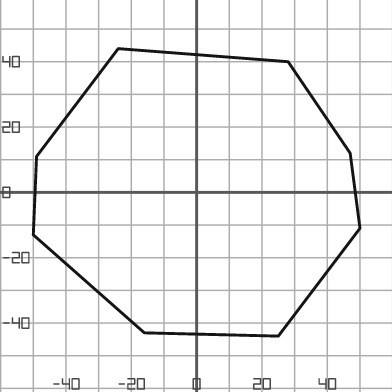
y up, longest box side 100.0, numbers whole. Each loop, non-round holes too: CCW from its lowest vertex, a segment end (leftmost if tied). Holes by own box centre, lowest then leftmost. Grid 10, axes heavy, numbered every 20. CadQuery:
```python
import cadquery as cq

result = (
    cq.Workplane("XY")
    .moveTo(25.0, -44.0)
    .lineTo(50.0, -11.0)
    .lineTo(47.0, 12.0)
    .lineTo(28.0, 40.0)
    .lineTo(-24.0, 44.0)
    .lineTo(-49.0, 11.0)
    .lineTo(-50.0, -13.0)
    .lineTo(-16.0, -43.0)
    .close()
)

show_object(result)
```